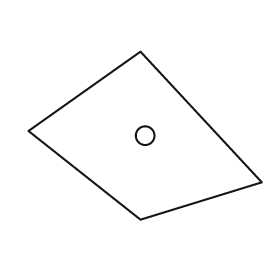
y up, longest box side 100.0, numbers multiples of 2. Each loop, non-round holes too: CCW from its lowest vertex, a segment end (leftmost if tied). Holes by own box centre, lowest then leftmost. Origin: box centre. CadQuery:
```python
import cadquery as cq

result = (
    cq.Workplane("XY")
    .moveTo(-2.0, -36.0)
    .lineTo(50.0, -20.0)
    .lineTo(-2.0, 36.0)
    .lineTo(-50.0, 2.0)
    .close()
    .moveTo(0.0, 0.0)
    .circle(4.0)
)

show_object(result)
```